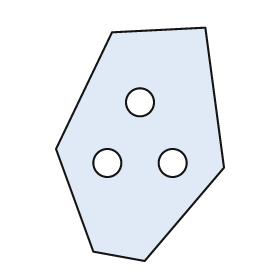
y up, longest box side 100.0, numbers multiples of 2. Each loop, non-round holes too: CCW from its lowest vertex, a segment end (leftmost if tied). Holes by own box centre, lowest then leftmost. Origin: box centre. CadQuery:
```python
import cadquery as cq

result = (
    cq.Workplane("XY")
    .moveTo(2.0, -50.0)
    .lineTo(36.0, -10.0)
    .lineTo(28.0, 50.0)
    .lineTo(-12.0, 48.0)
    .lineTo(-36.0, -2.0)
    .lineTo(-20.0, -46.0)
    .close()
    .moveTo(-14.0, -8.0)
    .circle(6.0)
    .moveTo(14.0, -8.0)
    .circle(6.0)
    .moveTo(0.0, 18.0)
    .circle(6.0)
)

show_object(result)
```